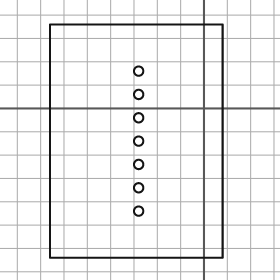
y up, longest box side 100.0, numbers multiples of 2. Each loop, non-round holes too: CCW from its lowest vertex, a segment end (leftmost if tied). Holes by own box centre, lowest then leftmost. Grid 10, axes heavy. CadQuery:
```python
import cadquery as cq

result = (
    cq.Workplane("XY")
    .moveTo(-66.0, -64.0)
    .lineTo(8.0, -64.0)
    .lineTo(8.0, 36.0)
    .lineTo(-66.0, 36.0)
    .close()
    .moveTo(-28.0, -44.0)
    .circle(2.0)
    .moveTo(-28.0, -34.0)
    .circle(2.0)
    .moveTo(-28.0, -24.0)
    .circle(2.0)
    .moveTo(-28.0, -14.0)
    .circle(2.0)
    .moveTo(-28.0, -4.0)
    .circle(2.0)
    .moveTo(-28.0, 6.0)
    .circle(2.0)
    .moveTo(-28.0, 16.0)
    .circle(2.0)
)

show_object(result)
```